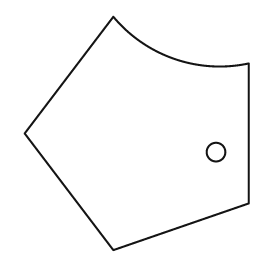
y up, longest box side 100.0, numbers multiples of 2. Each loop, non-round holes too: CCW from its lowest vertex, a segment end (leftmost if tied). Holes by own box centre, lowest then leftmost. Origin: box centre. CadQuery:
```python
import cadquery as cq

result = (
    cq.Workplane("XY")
    .moveTo(-10.0, -50.0)
    .lineTo(48.0, -30.0)
    .lineTo(48.0, 30.0)
    .threePointArc((16.0, 32.0), (-10.0, 50.0))
    .lineTo(-48.0, 0.0)
    .close()
    .moveTo(34.0, -8.0)
    .circle(4.0)
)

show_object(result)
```